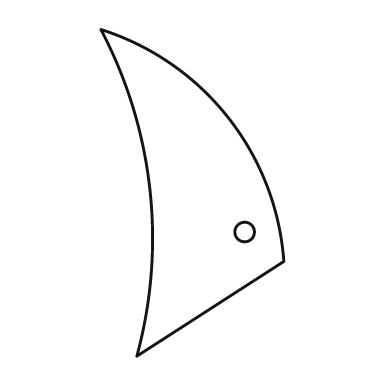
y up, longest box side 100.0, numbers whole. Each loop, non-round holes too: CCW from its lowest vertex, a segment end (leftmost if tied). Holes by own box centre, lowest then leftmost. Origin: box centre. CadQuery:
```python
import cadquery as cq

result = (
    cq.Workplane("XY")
    .moveTo(-17.0, -50.0)
    .lineTo(28.0, -21.0)
    .threePointArc((11.0, 23.0), (-28.0, 50.0))
    .threePointArc((-13.0, 1.0), (-17.0, -50.0))
    .close()
    .moveTo(16.0, -12.0)
    .circle(3.0)
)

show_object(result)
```